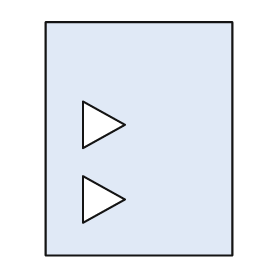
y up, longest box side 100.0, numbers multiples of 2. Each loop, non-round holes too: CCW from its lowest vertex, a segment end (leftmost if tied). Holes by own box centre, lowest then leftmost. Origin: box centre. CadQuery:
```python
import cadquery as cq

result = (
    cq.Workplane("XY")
    .moveTo(-40.0, -50.0)
    .lineTo(40.0, -50.0)
    .lineTo(40.0, 50.0)
    .lineTo(-40.0, 50.0)
    .close()
    .moveTo(-24.0, -36.0)
    .lineTo(-6.0, -26.0)
    .lineTo(-24.0, -16.0)
    .close()
    .moveTo(-24.0, -4.0)
    .lineTo(-6.0, 6.0)
    .lineTo(-24.0, 16.0)
    .close()
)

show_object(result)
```